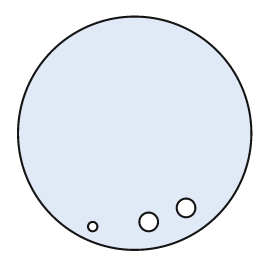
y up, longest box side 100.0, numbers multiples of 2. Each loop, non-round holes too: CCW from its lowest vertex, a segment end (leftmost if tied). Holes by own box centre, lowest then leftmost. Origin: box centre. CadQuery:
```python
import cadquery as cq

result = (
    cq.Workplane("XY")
    .moveTo(0.0, 0.0)
    .circle(50.0)
    .moveTo(-18.0, -40.0)
    .circle(2.0)
    .moveTo(6.0, -38.0)
    .circle(4.0)
    .moveTo(22.0, -32.0)
    .circle(4.0)
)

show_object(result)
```